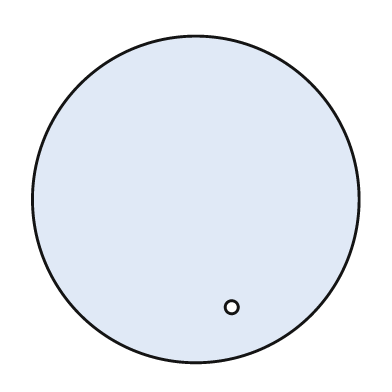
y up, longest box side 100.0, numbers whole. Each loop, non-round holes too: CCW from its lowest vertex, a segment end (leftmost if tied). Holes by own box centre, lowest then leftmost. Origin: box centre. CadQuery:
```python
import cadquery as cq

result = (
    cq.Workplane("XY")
    .moveTo(0.0, 0.0)
    .circle(50.0)
    .moveTo(11.0, -33.0)
    .circle(2.0)
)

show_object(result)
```